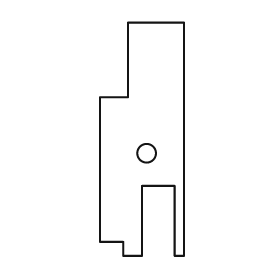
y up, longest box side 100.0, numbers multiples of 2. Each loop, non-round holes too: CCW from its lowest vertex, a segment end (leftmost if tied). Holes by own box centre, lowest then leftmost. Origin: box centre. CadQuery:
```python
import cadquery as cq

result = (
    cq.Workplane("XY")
    .moveTo(-8.0, -50.0)
    .lineTo(0.0, -50.0)
    .lineTo(0.0, -20.0)
    .lineTo(14.0, -20.0)
    .lineTo(14.0, -50.0)
    .lineTo(18.0, -50.0)
    .lineTo(18.0, 50.0)
    .lineTo(-6.0, 50.0)
    .lineTo(-6.0, 18.0)
    .lineTo(-18.0, 18.0)
    .lineTo(-18.0, -44.0)
    .lineTo(-8.0, -44.0)
    .close()
    .moveTo(2.0, -6.0)
    .circle(4.0)
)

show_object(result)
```